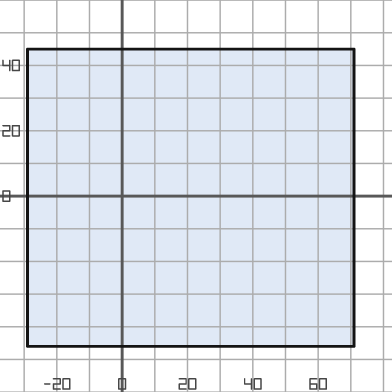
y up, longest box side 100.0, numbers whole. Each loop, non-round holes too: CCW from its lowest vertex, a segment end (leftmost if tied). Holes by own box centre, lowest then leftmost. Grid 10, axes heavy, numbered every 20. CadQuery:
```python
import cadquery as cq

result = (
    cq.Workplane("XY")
    .moveTo(-29.0, -46.0)
    .lineTo(71.0, -46.0)
    .lineTo(71.0, 45.0)
    .lineTo(-29.0, 45.0)
    .close()
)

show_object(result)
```